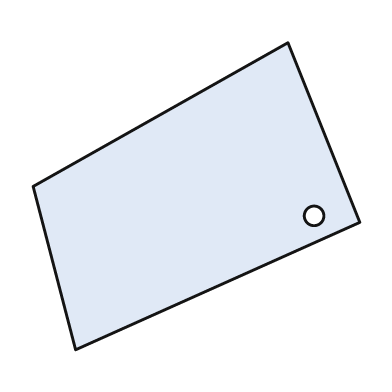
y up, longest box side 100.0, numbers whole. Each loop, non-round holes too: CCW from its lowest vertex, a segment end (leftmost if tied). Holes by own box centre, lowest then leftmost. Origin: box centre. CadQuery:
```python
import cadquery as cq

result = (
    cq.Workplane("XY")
    .moveTo(-37.0, -47.0)
    .lineTo(50.0, -8.0)
    .lineTo(28.0, 47.0)
    .lineTo(-50.0, 3.0)
    .close()
    .moveTo(36.0, -6.0)
    .circle(3.0)
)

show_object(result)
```